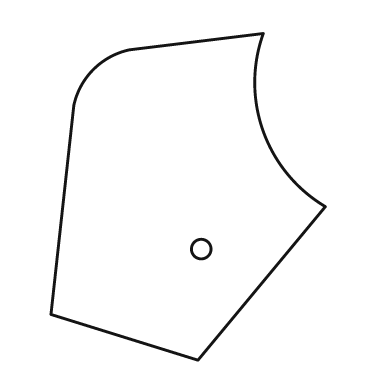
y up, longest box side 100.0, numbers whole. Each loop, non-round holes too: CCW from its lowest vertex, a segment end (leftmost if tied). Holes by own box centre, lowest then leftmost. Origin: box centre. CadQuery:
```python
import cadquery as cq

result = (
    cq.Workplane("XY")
    .moveTo(3.0, -50.0)
    .lineTo(42.0, -3.0)
    .threePointArc((23.0, 20.0), (23.0, 50.0))
    .lineTo(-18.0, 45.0)
    .threePointArc((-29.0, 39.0), (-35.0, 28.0))
    .lineTo(-42.0, -36.0)
    .close()
    .moveTo(4.0, -16.0)
    .circle(3.0)
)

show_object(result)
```